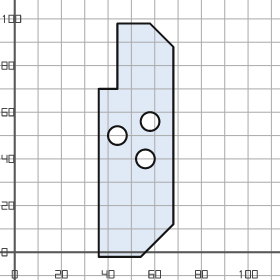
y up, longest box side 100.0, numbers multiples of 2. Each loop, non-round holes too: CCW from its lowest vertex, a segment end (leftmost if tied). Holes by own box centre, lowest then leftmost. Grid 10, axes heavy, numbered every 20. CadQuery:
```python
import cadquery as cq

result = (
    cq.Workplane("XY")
    .moveTo(36.0, -2.0)
    .lineTo(54.0, -2.0)
    .lineTo(68.0, 12.0)
    .lineTo(68.0, 88.0)
    .lineTo(58.0, 98.0)
    .lineTo(44.0, 98.0)
    .lineTo(44.0, 70.0)
    .lineTo(36.0, 70.0)
    .close()
    .moveTo(56.0, 40.0)
    .circle(4.0)
    .moveTo(44.0, 50.0)
    .circle(4.0)
    .moveTo(58.0, 56.0)
    .circle(4.0)
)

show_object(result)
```